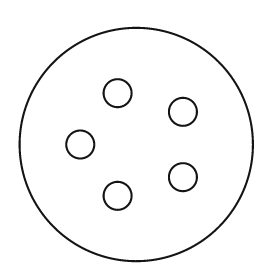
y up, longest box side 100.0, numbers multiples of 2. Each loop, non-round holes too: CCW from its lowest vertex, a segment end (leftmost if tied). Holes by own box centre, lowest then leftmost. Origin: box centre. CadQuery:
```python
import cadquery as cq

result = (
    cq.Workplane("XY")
    .moveTo(0.0, 0.0)
    .circle(50.0)
    .moveTo(-8.0, -22.0)
    .circle(6.0)
    .moveTo(20.0, -14.0)
    .circle(6.0)
    .moveTo(-24.0, 0.0)
    .circle(6.0)
    .moveTo(20.0, 14.0)
    .circle(6.0)
    .moveTo(-8.0, 22.0)
    .circle(6.0)
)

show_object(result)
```